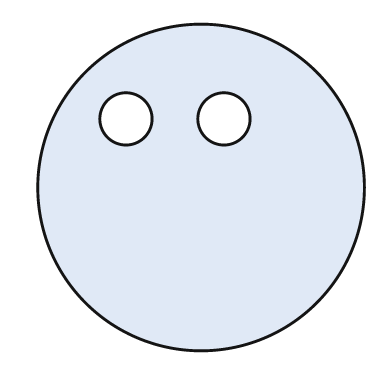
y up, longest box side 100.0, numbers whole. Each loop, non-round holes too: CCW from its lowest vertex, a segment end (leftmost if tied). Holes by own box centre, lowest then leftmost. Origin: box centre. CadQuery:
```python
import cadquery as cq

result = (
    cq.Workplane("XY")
    .moveTo(0.0, 0.0)
    .circle(50.0)
    .moveTo(-23.0, 21.0)
    .circle(8.0)
    .moveTo(7.0, 21.0)
    .circle(8.0)
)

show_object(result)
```